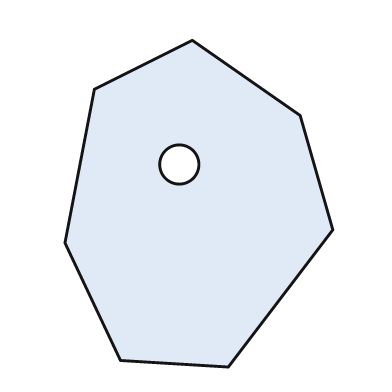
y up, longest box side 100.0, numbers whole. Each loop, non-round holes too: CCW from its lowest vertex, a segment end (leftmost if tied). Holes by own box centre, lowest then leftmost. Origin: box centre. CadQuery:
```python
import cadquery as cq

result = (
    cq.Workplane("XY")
    .moveTo(9.0, -50.0)
    .lineTo(41.0, -8.0)
    .lineTo(31.0, 27.0)
    .lineTo(-2.0, 50.0)
    .lineTo(-32.0, 35.0)
    .lineTo(-41.0, -12.0)
    .lineTo(-24.0, -48.0)
    .close()
    .moveTo(-6.0, 12.0)
    .circle(6.0)
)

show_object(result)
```